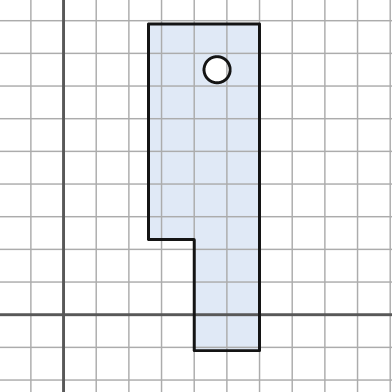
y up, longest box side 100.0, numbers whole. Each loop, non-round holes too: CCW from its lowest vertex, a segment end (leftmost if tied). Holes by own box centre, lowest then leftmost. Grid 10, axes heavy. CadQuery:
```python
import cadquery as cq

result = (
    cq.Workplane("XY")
    .moveTo(40.0, -11.0)
    .lineTo(60.0, -11.0)
    .lineTo(60.0, 89.0)
    .lineTo(26.0, 89.0)
    .lineTo(26.0, 23.0)
    .lineTo(40.0, 23.0)
    .close()
    .moveTo(47.0, 75.0)
    .circle(4.0)
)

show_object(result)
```